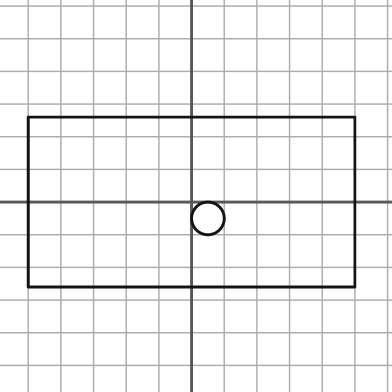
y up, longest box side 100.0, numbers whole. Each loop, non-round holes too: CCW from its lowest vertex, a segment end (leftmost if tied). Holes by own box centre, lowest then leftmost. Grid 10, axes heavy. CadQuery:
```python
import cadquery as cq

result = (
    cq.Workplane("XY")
    .moveTo(-50.0, -26.0)
    .lineTo(50.0, -26.0)
    .lineTo(50.0, 26.0)
    .lineTo(-50.0, 26.0)
    .close()
    .moveTo(5.0, -5.0)
    .circle(5.0)
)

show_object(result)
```